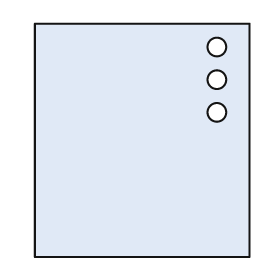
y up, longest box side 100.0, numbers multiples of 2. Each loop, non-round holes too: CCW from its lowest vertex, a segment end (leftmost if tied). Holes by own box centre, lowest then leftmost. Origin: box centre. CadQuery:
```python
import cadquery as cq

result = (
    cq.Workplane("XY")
    .moveTo(-46.0, -50.0)
    .lineTo(46.0, -50.0)
    .lineTo(46.0, 50.0)
    .lineTo(-46.0, 50.0)
    .close()
    .moveTo(32.0, 12.0)
    .circle(4.0)
    .moveTo(32.0, 26.0)
    .circle(4.0)
    .moveTo(32.0, 40.0)
    .circle(4.0)
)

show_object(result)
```